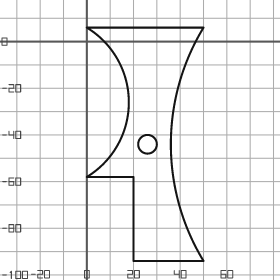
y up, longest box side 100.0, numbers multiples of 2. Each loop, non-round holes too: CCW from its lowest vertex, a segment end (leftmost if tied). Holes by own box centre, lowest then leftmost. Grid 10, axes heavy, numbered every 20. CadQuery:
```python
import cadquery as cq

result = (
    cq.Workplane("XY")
    .moveTo(20.0, -94.0)
    .lineTo(50.0, -94.0)
    .threePointArc((36.0, -44.0), (50.0, 6.0))
    .lineTo(0.0, 6.0)
    .threePointArc((18.0, -26.0), (0.0, -58.0))
    .lineTo(20.0, -58.0)
    .close()
    .moveTo(26.0, -44.0)
    .circle(4.0)
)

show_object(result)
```